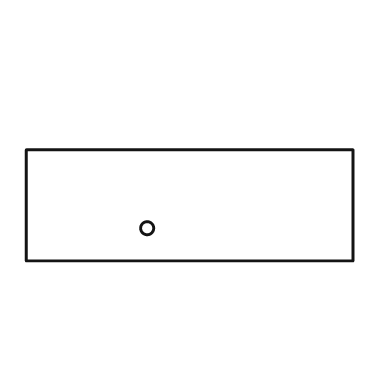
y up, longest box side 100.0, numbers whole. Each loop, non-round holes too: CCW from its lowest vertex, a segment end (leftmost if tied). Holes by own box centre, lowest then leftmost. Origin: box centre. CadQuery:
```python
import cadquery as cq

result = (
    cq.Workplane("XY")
    .moveTo(-50.0, -17.0)
    .lineTo(50.0, -17.0)
    .lineTo(50.0, 17.0)
    .lineTo(-50.0, 17.0)
    .close()
    .moveTo(-13.0, -7.0)
    .circle(2.0)
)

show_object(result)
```